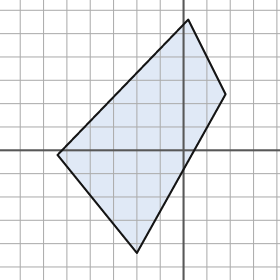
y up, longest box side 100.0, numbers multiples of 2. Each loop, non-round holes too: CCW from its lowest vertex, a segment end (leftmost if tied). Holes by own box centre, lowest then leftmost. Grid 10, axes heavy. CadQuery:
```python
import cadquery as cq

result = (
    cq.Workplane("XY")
    .moveTo(-20.0, -44.0)
    .lineTo(18.0, 24.0)
    .lineTo(2.0, 56.0)
    .lineTo(-54.0, -2.0)
    .close()
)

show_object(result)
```